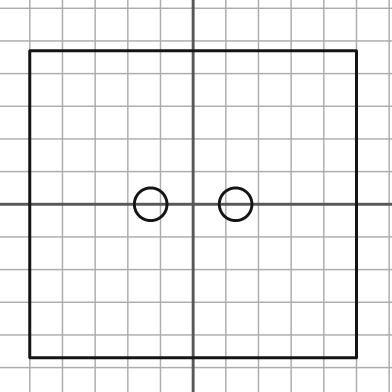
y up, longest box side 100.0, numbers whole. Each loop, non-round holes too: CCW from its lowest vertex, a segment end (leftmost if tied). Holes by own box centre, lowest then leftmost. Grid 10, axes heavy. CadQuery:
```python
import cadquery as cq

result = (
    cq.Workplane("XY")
    .moveTo(-50.0, -47.0)
    .lineTo(50.0, -47.0)
    .lineTo(50.0, 47.0)
    .lineTo(-50.0, 47.0)
    .close()
    .moveTo(-13.0, 0.0)
    .circle(5.0)
    .moveTo(13.0, 0.0)
    .circle(5.0)
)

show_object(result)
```